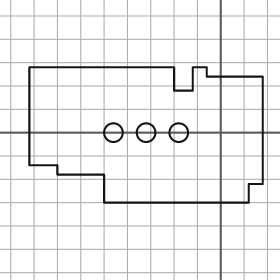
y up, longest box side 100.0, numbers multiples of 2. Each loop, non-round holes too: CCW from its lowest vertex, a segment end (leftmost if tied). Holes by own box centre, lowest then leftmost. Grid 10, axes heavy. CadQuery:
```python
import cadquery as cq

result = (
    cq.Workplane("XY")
    .moveTo(-50.0, -30.0)
    .lineTo(12.0, -30.0)
    .lineTo(12.0, -22.0)
    .lineTo(18.0, -22.0)
    .lineTo(18.0, 24.0)
    .lineTo(-6.0, 24.0)
    .lineTo(-6.0, 28.0)
    .lineTo(-12.0, 28.0)
    .lineTo(-12.0, 18.0)
    .lineTo(-20.0, 18.0)
    .lineTo(-20.0, 28.0)
    .lineTo(-82.0, 28.0)
    .lineTo(-82.0, -14.0)
    .lineTo(-70.0, -14.0)
    .lineTo(-70.0, -18.0)
    .lineTo(-50.0, -18.0)
    .close()
    .moveTo(-46.0, 0.0)
    .circle(4.0)
    .moveTo(-32.0, 0.0)
    .circle(4.0)
    .moveTo(-18.0, 0.0)
    .circle(4.0)
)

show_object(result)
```